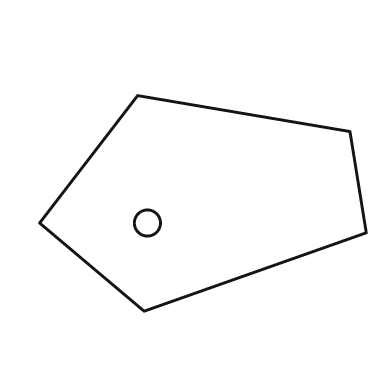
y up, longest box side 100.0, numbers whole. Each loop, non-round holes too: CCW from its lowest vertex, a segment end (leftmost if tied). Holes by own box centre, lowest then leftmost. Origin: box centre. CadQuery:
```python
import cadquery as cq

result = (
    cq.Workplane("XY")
    .moveTo(-18.0, -33.0)
    .lineTo(50.0, -9.0)
    .lineTo(45.0, 22.0)
    .lineTo(-20.0, 33.0)
    .lineTo(-50.0, -6.0)
    .close()
    .moveTo(-17.0, -6.0)
    .circle(4.0)
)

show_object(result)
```